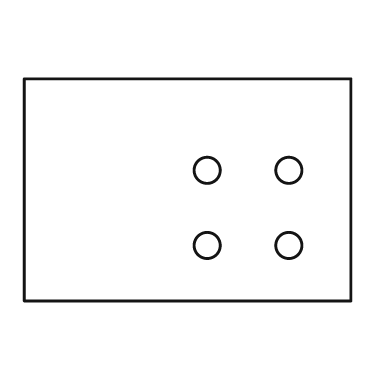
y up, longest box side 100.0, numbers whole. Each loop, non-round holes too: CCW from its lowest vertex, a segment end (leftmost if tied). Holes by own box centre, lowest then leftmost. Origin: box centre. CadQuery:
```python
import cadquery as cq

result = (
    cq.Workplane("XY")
    .moveTo(-50.0, -34.0)
    .lineTo(50.0, -34.0)
    .lineTo(50.0, 34.0)
    .lineTo(-50.0, 34.0)
    .close()
    .moveTo(6.0, -17.0)
    .circle(4.0)
    .moveTo(31.0, -17.0)
    .circle(4.0)
    .moveTo(6.0, 6.0)
    .circle(4.0)
    .moveTo(31.0, 6.0)
    .circle(4.0)
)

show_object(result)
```